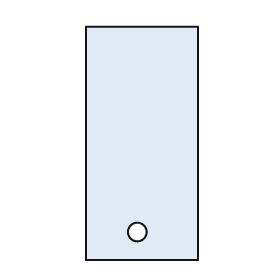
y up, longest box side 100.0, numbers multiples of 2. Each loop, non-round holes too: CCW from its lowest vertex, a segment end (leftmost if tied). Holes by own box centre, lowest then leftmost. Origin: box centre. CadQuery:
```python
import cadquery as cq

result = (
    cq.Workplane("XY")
    .moveTo(-24.0, -50.0)
    .lineTo(24.0, -50.0)
    .lineTo(24.0, 50.0)
    .lineTo(-24.0, 50.0)
    .close()
    .moveTo(-2.0, -38.0)
    .circle(4.0)
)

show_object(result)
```